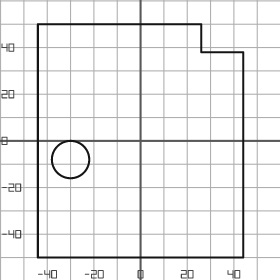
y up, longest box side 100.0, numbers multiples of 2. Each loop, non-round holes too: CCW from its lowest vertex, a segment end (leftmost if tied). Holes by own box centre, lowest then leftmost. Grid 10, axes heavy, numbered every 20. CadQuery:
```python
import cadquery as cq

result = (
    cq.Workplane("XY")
    .moveTo(-44.0, -50.0)
    .lineTo(44.0, -50.0)
    .lineTo(44.0, 38.0)
    .lineTo(26.0, 38.0)
    .lineTo(26.0, 50.0)
    .lineTo(-44.0, 50.0)
    .close()
    .moveTo(-30.0, -8.0)
    .circle(8.0)
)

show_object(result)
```